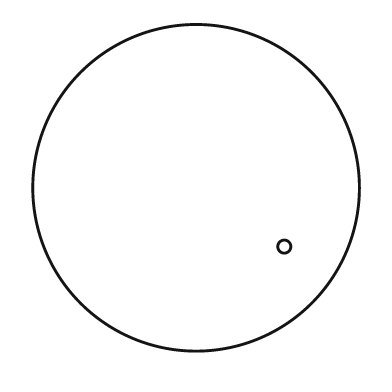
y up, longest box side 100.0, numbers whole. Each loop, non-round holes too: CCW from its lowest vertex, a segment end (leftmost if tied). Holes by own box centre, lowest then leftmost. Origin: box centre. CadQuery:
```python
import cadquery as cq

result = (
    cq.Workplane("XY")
    .moveTo(0.0, 0.0)
    .circle(50.0)
    .moveTo(27.0, -18.0)
    .circle(2.0)
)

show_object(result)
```